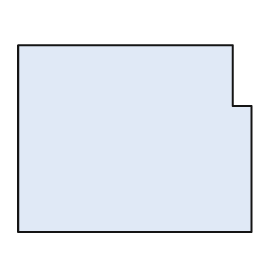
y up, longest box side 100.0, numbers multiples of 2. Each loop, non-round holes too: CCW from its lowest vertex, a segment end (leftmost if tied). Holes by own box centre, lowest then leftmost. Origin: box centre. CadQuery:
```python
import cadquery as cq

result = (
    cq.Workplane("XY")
    .moveTo(-50.0, -40.0)
    .lineTo(50.0, -40.0)
    .lineTo(50.0, 14.0)
    .lineTo(42.0, 14.0)
    .lineTo(42.0, 40.0)
    .lineTo(-50.0, 40.0)
    .close()
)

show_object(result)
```